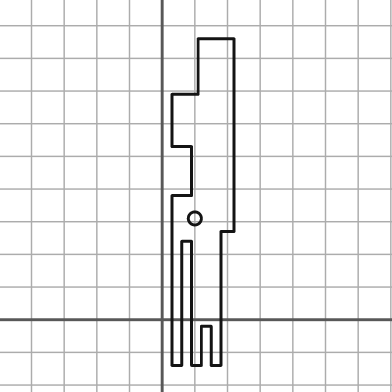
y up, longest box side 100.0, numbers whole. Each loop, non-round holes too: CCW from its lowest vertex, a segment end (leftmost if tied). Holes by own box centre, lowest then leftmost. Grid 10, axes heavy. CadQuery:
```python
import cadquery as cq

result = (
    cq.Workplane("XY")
    .moveTo(3.0, -14.0)
    .lineTo(6.0, -14.0)
    .lineTo(6.0, 24.0)
    .lineTo(9.0, 24.0)
    .lineTo(9.0, -14.0)
    .lineTo(12.0, -14.0)
    .lineTo(12.0, -2.0)
    .lineTo(15.0, -2.0)
    .lineTo(15.0, -14.0)
    .lineTo(18.0, -14.0)
    .lineTo(18.0, 27.0)
    .lineTo(22.0, 27.0)
    .lineTo(22.0, 86.0)
    .lineTo(11.0, 86.0)
    .lineTo(11.0, 69.0)
    .lineTo(3.0, 69.0)
    .lineTo(3.0, 53.0)
    .lineTo(9.0, 53.0)
    .lineTo(9.0, 38.0)
    .lineTo(3.0, 38.0)
    .close()
    .moveTo(10.0, 31.0)
    .circle(2.0)
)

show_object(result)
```